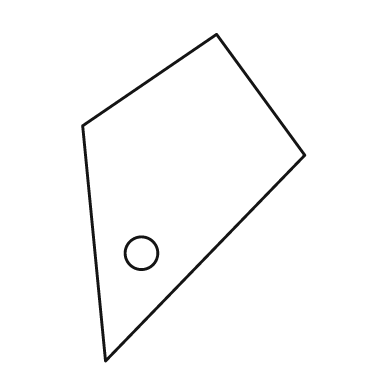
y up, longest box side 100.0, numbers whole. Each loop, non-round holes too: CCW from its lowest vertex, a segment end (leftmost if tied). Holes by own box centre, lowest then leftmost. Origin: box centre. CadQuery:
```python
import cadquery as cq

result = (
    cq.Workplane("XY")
    .moveTo(-27.0, -50.0)
    .lineTo(34.0, 13.0)
    .lineTo(7.0, 50.0)
    .lineTo(-34.0, 22.0)
    .close()
    .moveTo(-16.0, -17.0)
    .circle(5.0)
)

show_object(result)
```